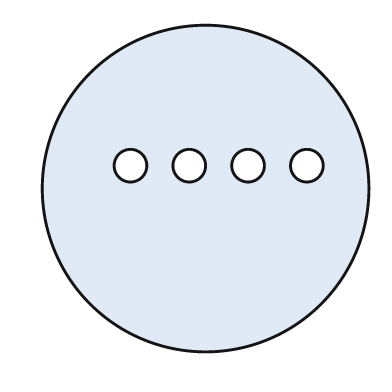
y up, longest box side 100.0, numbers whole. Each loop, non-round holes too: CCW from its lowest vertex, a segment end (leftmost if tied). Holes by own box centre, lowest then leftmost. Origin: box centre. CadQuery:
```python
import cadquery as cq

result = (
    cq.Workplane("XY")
    .moveTo(0.0, 0.0)
    .circle(50.0)
    .moveTo(-23.0, 7.0)
    .circle(5.0)
    .moveTo(-5.0, 7.0)
    .circle(5.0)
    .moveTo(13.0, 7.0)
    .circle(5.0)
    .moveTo(31.0, 7.0)
    .circle(5.0)
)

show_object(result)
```